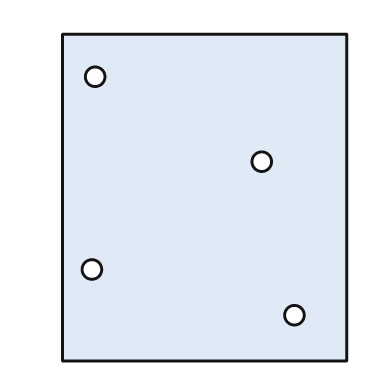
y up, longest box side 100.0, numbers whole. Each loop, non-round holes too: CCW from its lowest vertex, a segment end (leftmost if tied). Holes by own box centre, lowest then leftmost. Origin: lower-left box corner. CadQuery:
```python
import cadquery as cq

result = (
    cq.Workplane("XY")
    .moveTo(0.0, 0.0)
    .lineTo(87.0, 0.0)
    .lineTo(87.0, 100.0)
    .lineTo(0.0, 100.0)
    .close()
    .moveTo(71.0, 14.0)
    .circle(3.0)
    .moveTo(9.0, 28.0)
    .circle(3.0)
    .moveTo(61.0, 61.0)
    .circle(3.0)
    .moveTo(10.0, 87.0)
    .circle(3.0)
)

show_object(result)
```